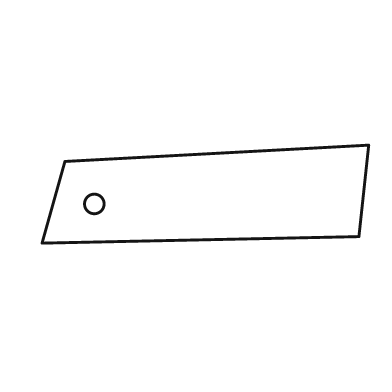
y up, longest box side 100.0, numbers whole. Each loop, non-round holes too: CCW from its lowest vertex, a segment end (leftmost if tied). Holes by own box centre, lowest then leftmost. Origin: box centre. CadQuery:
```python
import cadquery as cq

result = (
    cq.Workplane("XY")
    .moveTo(-50.0, -15.0)
    .lineTo(47.0, -13.0)
    .lineTo(50.0, 15.0)
    .lineTo(-43.0, 10.0)
    .close()
    .moveTo(-34.0, -3.0)
    .circle(3.0)
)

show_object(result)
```